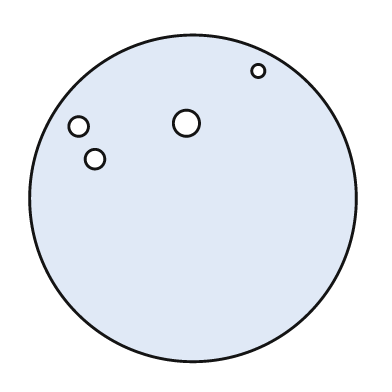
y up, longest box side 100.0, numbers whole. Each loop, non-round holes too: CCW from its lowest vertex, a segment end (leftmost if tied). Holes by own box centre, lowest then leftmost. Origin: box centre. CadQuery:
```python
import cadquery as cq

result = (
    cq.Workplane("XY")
    .moveTo(0.0, 0.0)
    .circle(50.0)
    .moveTo(-30.0, 12.0)
    .circle(3.0)
    .moveTo(-35.0, 22.0)
    .circle(3.0)
    .moveTo(-2.0, 23.0)
    .circle(4.0)
    .moveTo(20.0, 39.0)
    .circle(2.0)
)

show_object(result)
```